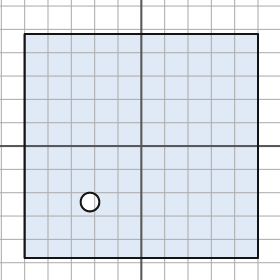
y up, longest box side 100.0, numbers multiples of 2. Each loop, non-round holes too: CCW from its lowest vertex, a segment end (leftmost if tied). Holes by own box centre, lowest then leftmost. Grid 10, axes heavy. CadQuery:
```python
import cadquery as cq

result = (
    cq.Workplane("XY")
    .moveTo(-50.0, -48.0)
    .lineTo(50.0, -48.0)
    .lineTo(50.0, 48.0)
    .lineTo(-50.0, 48.0)
    .close()
    .moveTo(-22.0, -24.0)
    .circle(4.0)
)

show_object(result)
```